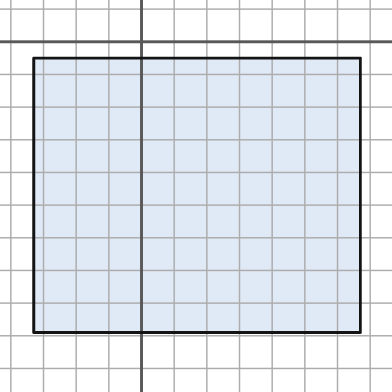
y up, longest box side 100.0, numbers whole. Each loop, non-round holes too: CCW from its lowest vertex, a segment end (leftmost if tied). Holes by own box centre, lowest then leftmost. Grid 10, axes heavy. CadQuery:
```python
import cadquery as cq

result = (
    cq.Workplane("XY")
    .moveTo(-33.0, -89.0)
    .lineTo(67.0, -89.0)
    .lineTo(67.0, -5.0)
    .lineTo(-33.0, -5.0)
    .close()
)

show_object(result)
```